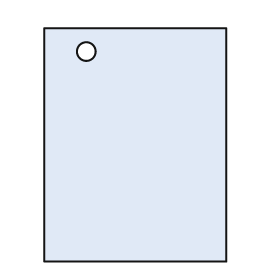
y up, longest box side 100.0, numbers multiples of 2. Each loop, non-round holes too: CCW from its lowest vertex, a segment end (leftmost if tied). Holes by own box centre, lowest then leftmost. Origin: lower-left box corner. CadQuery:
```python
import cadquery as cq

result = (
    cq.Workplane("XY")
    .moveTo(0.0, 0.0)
    .lineTo(78.0, 0.0)
    .lineTo(78.0, 100.0)
    .lineTo(0.0, 100.0)
    .close()
    .moveTo(18.0, 90.0)
    .circle(4.0)
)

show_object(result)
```